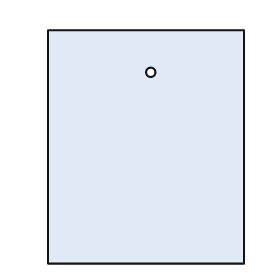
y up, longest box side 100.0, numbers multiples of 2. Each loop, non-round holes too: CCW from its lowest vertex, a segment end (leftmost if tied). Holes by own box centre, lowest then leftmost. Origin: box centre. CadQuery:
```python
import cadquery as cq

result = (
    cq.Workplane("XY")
    .moveTo(-42.0, -50.0)
    .lineTo(42.0, -50.0)
    .lineTo(42.0, 50.0)
    .lineTo(-42.0, 50.0)
    .close()
    .moveTo(2.0, 32.0)
    .circle(2.0)
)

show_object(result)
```